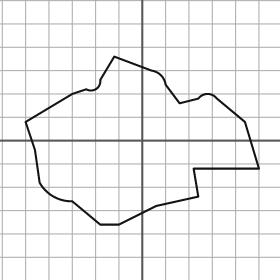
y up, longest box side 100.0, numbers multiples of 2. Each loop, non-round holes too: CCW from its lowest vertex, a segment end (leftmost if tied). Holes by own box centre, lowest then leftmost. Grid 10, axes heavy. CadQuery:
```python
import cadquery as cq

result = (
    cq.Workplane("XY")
    .moveTo(-18.0, -36.0)
    .lineTo(-10.0, -36.0)
    .lineTo(6.0, -28.0)
    .lineTo(24.0, -24.0)
    .lineTo(22.0, -12.0)
    .lineTo(50.0, -12.0)
    .lineTo(44.0, 8.0)
    .lineTo(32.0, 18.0)
    .threePointArc((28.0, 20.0), (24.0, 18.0))
    .lineTo(16.0, 16.0)
    .lineTo(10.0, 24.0)
    .threePointArc((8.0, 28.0), (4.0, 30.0))
    .lineTo(-12.0, 36.0)
    .lineTo(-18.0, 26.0)
    .threePointArc((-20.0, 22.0), (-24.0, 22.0))
    .lineTo(-30.0, 20.0)
    .lineTo(-50.0, 8.0)
    .lineTo(-46.0, -4.0)
    .lineTo(-44.0, -18.0)
    .threePointArc((-38.0, -24.0), (-30.0, -26.0))
    .close()
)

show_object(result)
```